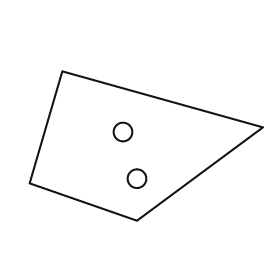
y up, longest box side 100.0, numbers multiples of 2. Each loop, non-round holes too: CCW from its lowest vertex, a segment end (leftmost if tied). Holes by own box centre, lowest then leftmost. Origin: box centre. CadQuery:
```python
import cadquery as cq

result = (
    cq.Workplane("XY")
    .moveTo(-4.0, -32.0)
    .lineTo(50.0, 8.0)
    .lineTo(-36.0, 32.0)
    .lineTo(-50.0, -16.0)
    .close()
    .moveTo(-4.0, -14.0)
    .circle(4.0)
    .moveTo(-10.0, 6.0)
    .circle(4.0)
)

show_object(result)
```